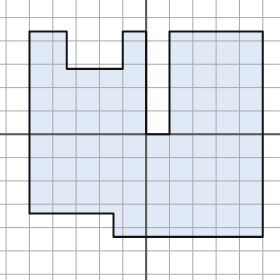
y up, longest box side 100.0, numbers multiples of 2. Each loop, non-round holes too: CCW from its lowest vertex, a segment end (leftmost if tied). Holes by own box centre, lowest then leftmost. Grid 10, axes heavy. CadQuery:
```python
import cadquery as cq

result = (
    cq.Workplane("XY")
    .moveTo(-14.0, -44.0)
    .lineTo(50.0, -44.0)
    .lineTo(50.0, 44.0)
    .lineTo(10.0, 44.0)
    .lineTo(10.0, 0.0)
    .lineTo(0.0, 0.0)
    .lineTo(0.0, 44.0)
    .lineTo(-10.0, 44.0)
    .lineTo(-10.0, 28.0)
    .lineTo(-34.0, 28.0)
    .lineTo(-34.0, 44.0)
    .lineTo(-50.0, 44.0)
    .lineTo(-50.0, -34.0)
    .lineTo(-14.0, -34.0)
    .close()
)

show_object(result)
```